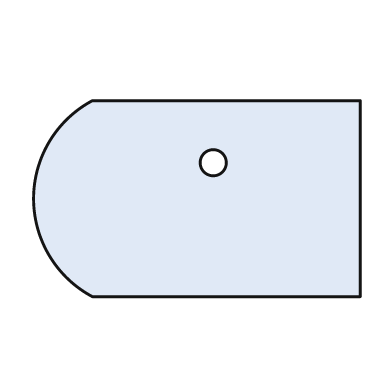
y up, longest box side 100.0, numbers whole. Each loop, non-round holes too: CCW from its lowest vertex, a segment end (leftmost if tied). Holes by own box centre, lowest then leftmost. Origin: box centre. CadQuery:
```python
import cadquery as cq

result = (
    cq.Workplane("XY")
    .moveTo(-32.0, -30.0)
    .lineTo(50.0, -30.0)
    .lineTo(50.0, 30.0)
    .lineTo(-32.0, 30.0)
    .threePointArc((-50.0, 0.0), (-32.0, -30.0))
    .close()
    .moveTo(5.0, 11.0)
    .circle(4.0)
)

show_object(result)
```